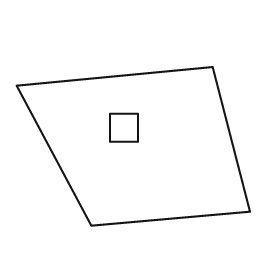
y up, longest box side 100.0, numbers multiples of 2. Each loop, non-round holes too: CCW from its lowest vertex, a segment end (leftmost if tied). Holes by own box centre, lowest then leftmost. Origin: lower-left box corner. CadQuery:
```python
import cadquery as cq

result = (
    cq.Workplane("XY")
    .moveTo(32.0, 0.0)
    .lineTo(100.0, 6.0)
    .lineTo(84.0, 68.0)
    .lineTo(0.0, 60.0)
    .close()
    .moveTo(40.0, 36.0)
    .lineTo(52.0, 36.0)
    .lineTo(52.0, 48.0)
    .lineTo(40.0, 48.0)
    .close()
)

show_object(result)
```